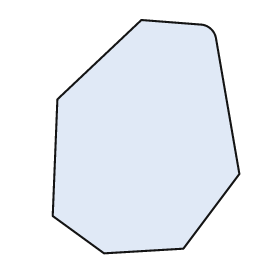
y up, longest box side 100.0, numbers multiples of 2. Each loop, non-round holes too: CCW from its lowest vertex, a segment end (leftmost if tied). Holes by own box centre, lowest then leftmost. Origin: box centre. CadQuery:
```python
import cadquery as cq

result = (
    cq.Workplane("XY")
    .moveTo(-18.0, -50.0)
    .lineTo(16.0, -48.0)
    .lineTo(40.0, -16.0)
    .lineTo(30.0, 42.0)
    .threePointArc((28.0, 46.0), (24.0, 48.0))
    .lineTo(-2.0, 50.0)
    .lineTo(-38.0, 16.0)
    .lineTo(-40.0, -34.0)
    .close()
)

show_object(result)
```